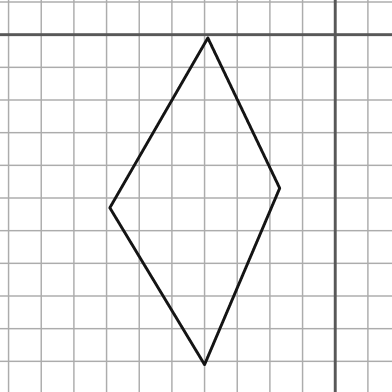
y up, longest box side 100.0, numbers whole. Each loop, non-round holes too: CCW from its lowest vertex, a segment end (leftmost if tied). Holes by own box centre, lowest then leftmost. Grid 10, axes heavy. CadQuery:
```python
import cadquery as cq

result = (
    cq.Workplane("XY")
    .moveTo(-40.0, -101.0)
    .lineTo(-17.0, -47.0)
    .lineTo(-39.0, -1.0)
    .lineTo(-69.0, -53.0)
    .close()
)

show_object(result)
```